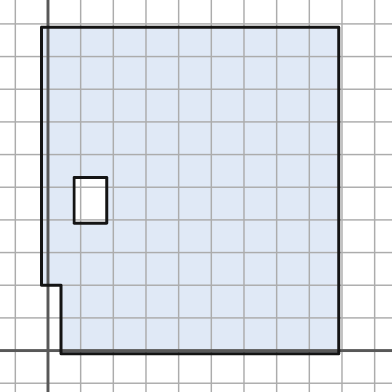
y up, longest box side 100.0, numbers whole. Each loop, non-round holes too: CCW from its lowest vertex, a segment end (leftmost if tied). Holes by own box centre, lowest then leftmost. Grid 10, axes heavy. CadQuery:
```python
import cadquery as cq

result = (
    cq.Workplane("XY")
    .moveTo(4.0, -1.0)
    .lineTo(89.0, -1.0)
    .lineTo(89.0, 99.0)
    .lineTo(-2.0, 99.0)
    .lineTo(-2.0, 20.0)
    .lineTo(4.0, 20.0)
    .close()
    .moveTo(8.0, 39.0)
    .lineTo(18.0, 39.0)
    .lineTo(18.0, 53.0)
    .lineTo(8.0, 53.0)
    .close()
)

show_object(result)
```